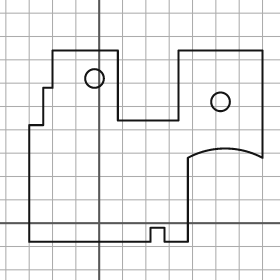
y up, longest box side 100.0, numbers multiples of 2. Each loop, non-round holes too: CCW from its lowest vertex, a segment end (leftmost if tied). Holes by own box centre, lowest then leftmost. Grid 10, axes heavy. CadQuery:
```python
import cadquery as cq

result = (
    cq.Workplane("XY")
    .moveTo(-30.0, -8.0)
    .lineTo(22.0, -8.0)
    .lineTo(22.0, -2.0)
    .lineTo(28.0, -2.0)
    .lineTo(28.0, -8.0)
    .lineTo(38.0, -8.0)
    .lineTo(38.0, 28.0)
    .threePointArc((54.0, 32.0), (70.0, 28.0))
    .lineTo(70.0, 74.0)
    .lineTo(34.0, 74.0)
    .lineTo(34.0, 44.0)
    .lineTo(8.0, 44.0)
    .lineTo(8.0, 74.0)
    .lineTo(-20.0, 74.0)
    .lineTo(-20.0, 58.0)
    .lineTo(-24.0, 58.0)
    .lineTo(-24.0, 42.0)
    .lineTo(-30.0, 42.0)
    .close()
    .moveTo(52.0, 52.0)
    .circle(4.0)
    .moveTo(-2.0, 62.0)
    .circle(4.0)
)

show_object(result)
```